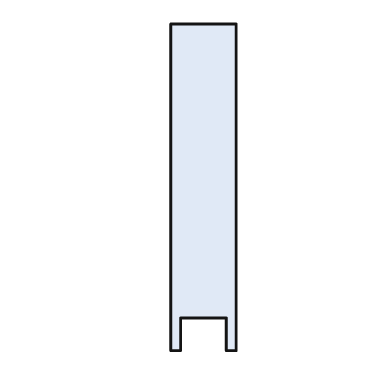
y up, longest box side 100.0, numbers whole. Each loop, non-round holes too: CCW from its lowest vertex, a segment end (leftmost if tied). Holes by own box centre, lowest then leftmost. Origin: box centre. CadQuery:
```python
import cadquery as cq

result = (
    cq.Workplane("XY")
    .moveTo(-10.0, -50.0)
    .lineTo(-7.0, -50.0)
    .lineTo(-7.0, -40.0)
    .lineTo(7.0, -40.0)
    .lineTo(7.0, -50.0)
    .lineTo(10.0, -50.0)
    .lineTo(10.0, 50.0)
    .lineTo(-10.0, 50.0)
    .close()
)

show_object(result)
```